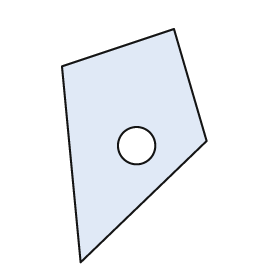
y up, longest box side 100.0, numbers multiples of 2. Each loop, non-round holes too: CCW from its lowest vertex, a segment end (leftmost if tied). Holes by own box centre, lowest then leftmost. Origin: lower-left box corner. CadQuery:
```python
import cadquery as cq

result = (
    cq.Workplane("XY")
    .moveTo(8.0, 0.0)
    .lineTo(62.0, 52.0)
    .lineTo(48.0, 100.0)
    .lineTo(0.0, 84.0)
    .close()
    .moveTo(32.0, 50.0)
    .circle(8.0)
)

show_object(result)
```